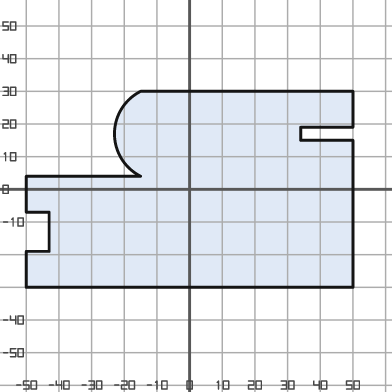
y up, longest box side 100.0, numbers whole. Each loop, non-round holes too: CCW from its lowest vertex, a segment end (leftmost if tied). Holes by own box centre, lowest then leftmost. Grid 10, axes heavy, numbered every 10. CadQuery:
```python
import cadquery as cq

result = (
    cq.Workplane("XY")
    .moveTo(-50.0, -30.0)
    .lineTo(50.0, -30.0)
    .lineTo(50.0, 15.0)
    .lineTo(34.0, 15.0)
    .lineTo(34.0, 19.0)
    .lineTo(50.0, 19.0)
    .lineTo(50.0, 30.0)
    .lineTo(-15.0, 30.0)
    .threePointArc((-23.0, 17.0), (-15.0, 4.0))
    .lineTo(-50.0, 4.0)
    .lineTo(-50.0, -7.0)
    .lineTo(-43.0, -7.0)
    .lineTo(-43.0, -19.0)
    .lineTo(-50.0, -19.0)
    .close()
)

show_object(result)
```